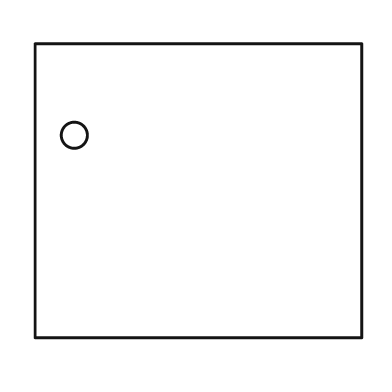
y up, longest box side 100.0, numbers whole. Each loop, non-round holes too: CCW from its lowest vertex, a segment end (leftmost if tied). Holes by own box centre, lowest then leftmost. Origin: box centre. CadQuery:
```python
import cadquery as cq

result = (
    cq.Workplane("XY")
    .moveTo(-50.0, -45.0)
    .lineTo(50.0, -45.0)
    .lineTo(50.0, 45.0)
    .lineTo(-50.0, 45.0)
    .close()
    .moveTo(-38.0, 17.0)
    .circle(4.0)
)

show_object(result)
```